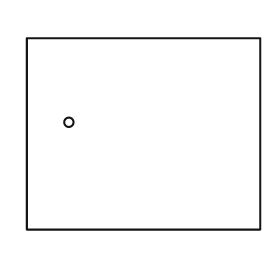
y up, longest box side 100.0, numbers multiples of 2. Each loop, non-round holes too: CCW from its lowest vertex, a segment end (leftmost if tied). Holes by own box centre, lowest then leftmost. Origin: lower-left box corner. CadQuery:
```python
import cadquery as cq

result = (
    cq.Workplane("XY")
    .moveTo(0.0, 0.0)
    .lineTo(100.0, 0.0)
    .lineTo(100.0, 82.0)
    .lineTo(0.0, 82.0)
    .close()
    .moveTo(18.0, 46.0)
    .circle(2.0)
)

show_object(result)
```